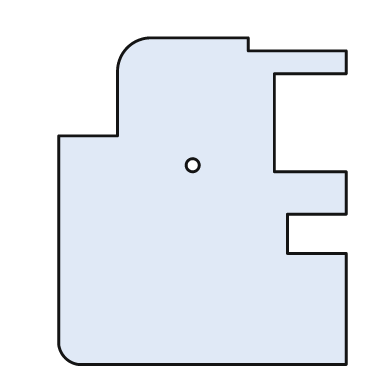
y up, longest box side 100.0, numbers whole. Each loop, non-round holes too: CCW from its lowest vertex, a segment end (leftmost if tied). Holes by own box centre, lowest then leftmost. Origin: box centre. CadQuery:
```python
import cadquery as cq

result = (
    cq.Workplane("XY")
    .moveTo(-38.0, -50.0)
    .lineTo(44.0, -50.0)
    .lineTo(44.0, -16.0)
    .lineTo(26.0, -16.0)
    .lineTo(26.0, -4.0)
    .lineTo(44.0, -4.0)
    .lineTo(44.0, 9.0)
    .lineTo(22.0, 9.0)
    .lineTo(22.0, 39.0)
    .lineTo(44.0, 39.0)
    .lineTo(44.0, 46.0)
    .lineTo(14.0, 46.0)
    .lineTo(14.0, 50.0)
    .lineTo(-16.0, 50.0)
    .threePointArc((-23.0, 47.0), (-26.0, 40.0))
    .lineTo(-26.0, 20.0)
    .lineTo(-44.0, 20.0)
    .lineTo(-44.0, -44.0)
    .threePointArc((-42.0, -48.0), (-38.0, -50.0))
    .close()
    .moveTo(-3.0, 11.0)
    .circle(2.0)
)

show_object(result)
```